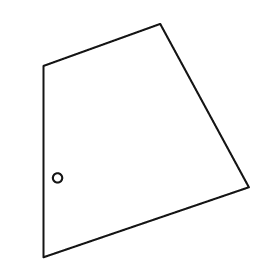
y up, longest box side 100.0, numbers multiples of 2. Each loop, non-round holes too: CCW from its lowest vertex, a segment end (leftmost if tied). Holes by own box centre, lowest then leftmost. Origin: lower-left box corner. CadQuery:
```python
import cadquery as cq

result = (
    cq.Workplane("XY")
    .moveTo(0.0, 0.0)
    .lineTo(88.0, 30.0)
    .lineTo(50.0, 100.0)
    .lineTo(0.0, 82.0)
    .close()
    .moveTo(6.0, 34.0)
    .circle(2.0)
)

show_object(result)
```